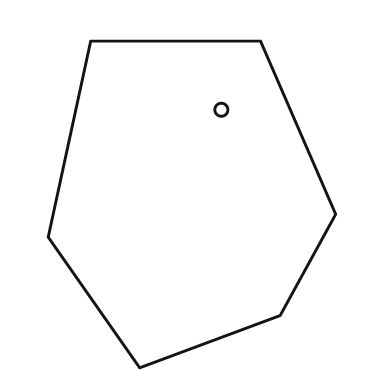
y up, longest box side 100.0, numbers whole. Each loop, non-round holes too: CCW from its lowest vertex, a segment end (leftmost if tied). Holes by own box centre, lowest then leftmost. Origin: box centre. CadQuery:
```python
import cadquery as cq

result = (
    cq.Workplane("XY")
    .moveTo(-16.0, -50.0)
    .lineTo(27.0, -34.0)
    .lineTo(44.0, -3.0)
    .lineTo(21.0, 50.0)
    .lineTo(-31.0, 50.0)
    .lineTo(-44.0, -10.0)
    .close()
    .moveTo(9.0, 29.0)
    .circle(2.0)
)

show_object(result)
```